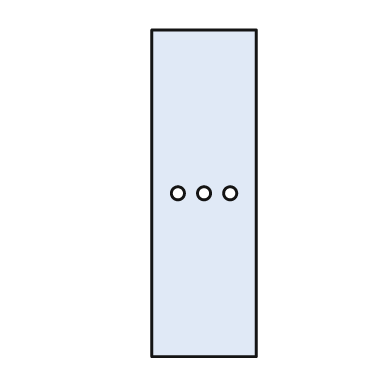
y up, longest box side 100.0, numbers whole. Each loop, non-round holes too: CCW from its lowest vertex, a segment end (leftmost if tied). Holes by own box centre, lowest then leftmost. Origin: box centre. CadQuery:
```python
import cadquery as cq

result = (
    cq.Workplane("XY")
    .moveTo(-16.0, -50.0)
    .lineTo(16.0, -50.0)
    .lineTo(16.0, 50.0)
    .lineTo(-16.0, 50.0)
    .close()
    .moveTo(-8.0, 0.0)
    .circle(2.0)
    .moveTo(0.0, 0.0)
    .circle(2.0)
    .moveTo(8.0, 0.0)
    .circle(2.0)
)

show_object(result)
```